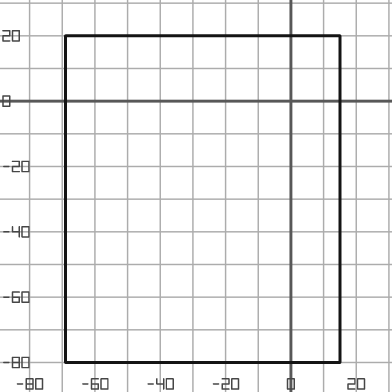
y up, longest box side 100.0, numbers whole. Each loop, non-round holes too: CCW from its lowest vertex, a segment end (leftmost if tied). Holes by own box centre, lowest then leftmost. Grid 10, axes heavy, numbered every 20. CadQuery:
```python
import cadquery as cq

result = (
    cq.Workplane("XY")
    .moveTo(-69.0, -80.0)
    .lineTo(15.0, -80.0)
    .lineTo(15.0, 20.0)
    .lineTo(-69.0, 20.0)
    .close()
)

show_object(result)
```